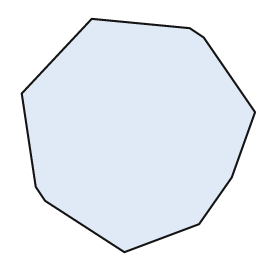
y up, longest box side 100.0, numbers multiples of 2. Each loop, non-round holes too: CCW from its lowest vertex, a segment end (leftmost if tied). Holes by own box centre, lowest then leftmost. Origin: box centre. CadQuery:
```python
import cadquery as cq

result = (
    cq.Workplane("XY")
    .moveTo(-6.0, -50.0)
    .lineTo(26.0, -38.0)
    .lineTo(40.0, -18.0)
    .lineTo(50.0, 10.0)
    .lineTo(28.0, 42.0)
    .lineTo(22.0, 46.0)
    .lineTo(-20.0, 50.0)
    .lineTo(-50.0, 18.0)
    .lineTo(-44.0, -22.0)
    .lineTo(-40.0, -28.0)
    .close()
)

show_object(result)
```